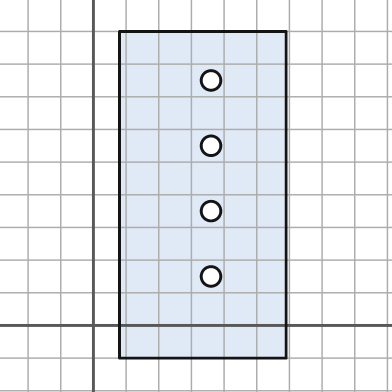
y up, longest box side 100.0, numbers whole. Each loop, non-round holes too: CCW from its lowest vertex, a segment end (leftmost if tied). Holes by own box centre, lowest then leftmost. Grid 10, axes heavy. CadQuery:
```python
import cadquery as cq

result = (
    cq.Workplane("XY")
    .moveTo(8.0, -10.0)
    .lineTo(59.0, -10.0)
    .lineTo(59.0, 90.0)
    .lineTo(8.0, 90.0)
    .close()
    .moveTo(36.0, 15.0)
    .circle(3.0)
    .moveTo(36.0, 35.0)
    .circle(3.0)
    .moveTo(36.0, 55.0)
    .circle(3.0)
    .moveTo(36.0, 75.0)
    .circle(3.0)
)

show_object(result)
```